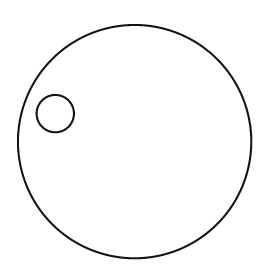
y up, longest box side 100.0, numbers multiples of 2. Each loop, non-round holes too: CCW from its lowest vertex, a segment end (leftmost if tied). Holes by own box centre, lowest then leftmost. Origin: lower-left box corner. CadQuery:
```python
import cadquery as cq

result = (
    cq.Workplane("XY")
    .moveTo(50.0, 50.0)
    .circle(50.0)
    .moveTo(16.0, 62.0)
    .circle(8.0)
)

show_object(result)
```